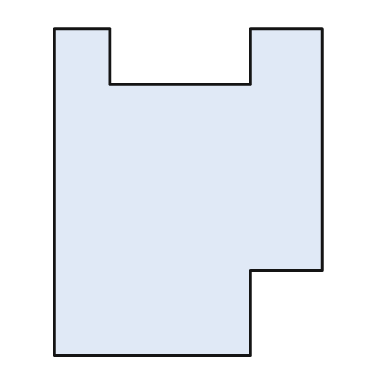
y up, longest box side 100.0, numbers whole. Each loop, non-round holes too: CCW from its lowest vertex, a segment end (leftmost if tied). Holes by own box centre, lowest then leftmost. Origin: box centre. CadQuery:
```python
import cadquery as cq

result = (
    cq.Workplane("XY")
    .moveTo(-41.0, -50.0)
    .lineTo(19.0, -50.0)
    .lineTo(19.0, -24.0)
    .lineTo(41.0, -24.0)
    .lineTo(41.0, 50.0)
    .lineTo(19.0, 50.0)
    .lineTo(19.0, 33.0)
    .lineTo(-24.0, 33.0)
    .lineTo(-24.0, 50.0)
    .lineTo(-41.0, 50.0)
    .close()
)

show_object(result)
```